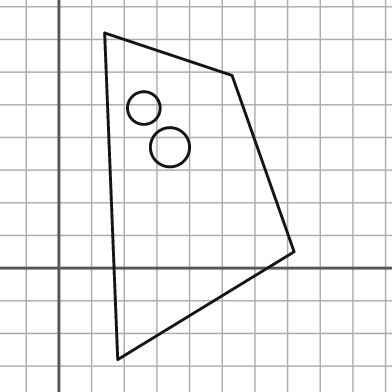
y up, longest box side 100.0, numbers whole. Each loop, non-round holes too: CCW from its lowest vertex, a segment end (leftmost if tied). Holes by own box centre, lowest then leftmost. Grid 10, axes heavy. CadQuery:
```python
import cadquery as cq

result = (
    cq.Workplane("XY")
    .moveTo(18.0, -28.0)
    .lineTo(72.0, 5.0)
    .lineTo(53.0, 59.0)
    .lineTo(14.0, 72.0)
    .close()
    .moveTo(34.0, 37.0)
    .circle(6.0)
    .moveTo(26.0, 49.0)
    .circle(5.0)
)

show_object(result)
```